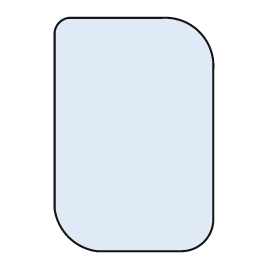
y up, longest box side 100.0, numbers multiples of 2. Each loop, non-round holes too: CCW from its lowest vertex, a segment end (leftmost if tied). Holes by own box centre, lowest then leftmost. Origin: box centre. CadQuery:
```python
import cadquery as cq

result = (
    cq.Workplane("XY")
    .moveTo(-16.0, -50.0)
    .lineTo(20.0, -50.0)
    .threePointArc((30.0, -46.0), (34.0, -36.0))
    .lineTo(34.0, 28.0)
    .threePointArc((28.0, 44.0), (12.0, 50.0))
    .lineTo(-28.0, 50.0)
    .threePointArc((-32.0, 48.0), (-34.0, 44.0))
    .lineTo(-34.0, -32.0)
    .threePointArc((-28.0, -44.0), (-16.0, -50.0))
    .close()
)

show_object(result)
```